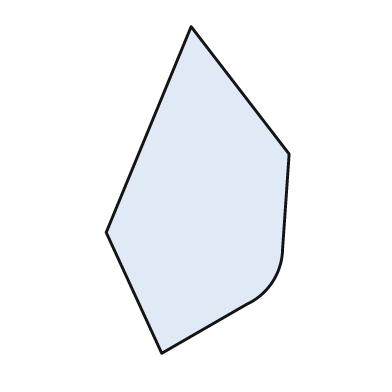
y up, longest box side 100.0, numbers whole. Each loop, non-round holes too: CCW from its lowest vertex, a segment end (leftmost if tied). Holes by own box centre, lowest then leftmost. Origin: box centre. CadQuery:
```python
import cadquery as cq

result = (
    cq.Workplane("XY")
    .moveTo(-11.0, -50.0)
    .lineTo(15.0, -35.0)
    .threePointArc((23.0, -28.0), (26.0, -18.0))
    .lineTo(28.0, 11.0)
    .lineTo(-2.0, 50.0)
    .lineTo(-28.0, -13.0)
    .close()
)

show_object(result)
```